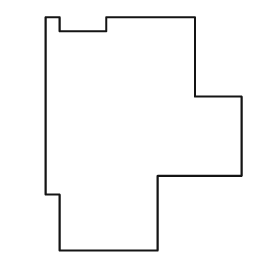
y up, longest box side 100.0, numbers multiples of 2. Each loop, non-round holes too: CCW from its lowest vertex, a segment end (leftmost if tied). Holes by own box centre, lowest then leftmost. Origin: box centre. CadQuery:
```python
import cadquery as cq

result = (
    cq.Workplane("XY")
    .moveTo(-36.0, -50.0)
    .lineTo(6.0, -50.0)
    .lineTo(6.0, -18.0)
    .lineTo(42.0, -18.0)
    .lineTo(42.0, 16.0)
    .lineTo(22.0, 16.0)
    .lineTo(22.0, 50.0)
    .lineTo(-16.0, 50.0)
    .lineTo(-16.0, 44.0)
    .lineTo(-36.0, 44.0)
    .lineTo(-36.0, 50.0)
    .lineTo(-42.0, 50.0)
    .lineTo(-42.0, -26.0)
    .lineTo(-36.0, -26.0)
    .close()
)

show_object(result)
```